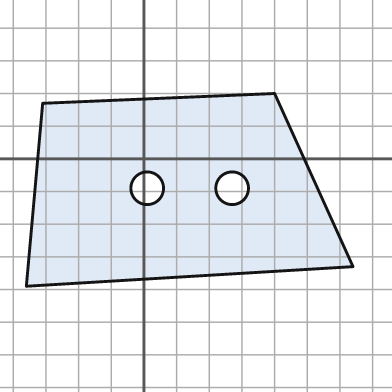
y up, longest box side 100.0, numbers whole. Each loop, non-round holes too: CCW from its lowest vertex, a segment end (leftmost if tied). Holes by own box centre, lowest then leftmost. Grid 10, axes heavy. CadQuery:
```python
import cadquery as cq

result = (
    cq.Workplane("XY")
    .moveTo(-36.0, -39.0)
    .lineTo(64.0, -33.0)
    .lineTo(40.0, 20.0)
    .lineTo(-31.0, 17.0)
    .close()
    .moveTo(1.0, -9.0)
    .circle(5.0)
    .moveTo(27.0, -9.0)
    .circle(5.0)
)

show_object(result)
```